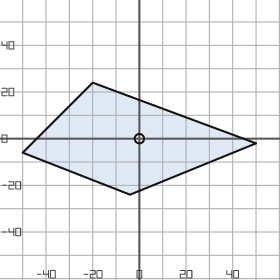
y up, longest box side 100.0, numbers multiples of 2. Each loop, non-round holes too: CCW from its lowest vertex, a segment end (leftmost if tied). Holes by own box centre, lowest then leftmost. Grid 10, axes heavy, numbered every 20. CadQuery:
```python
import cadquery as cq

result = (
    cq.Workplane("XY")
    .moveTo(-4.0, -24.0)
    .lineTo(50.0, -2.0)
    .lineTo(-20.0, 24.0)
    .lineTo(-50.0, -6.0)
    .close()
    .moveTo(0.0, 0.0)
    .circle(2.0)
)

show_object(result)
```